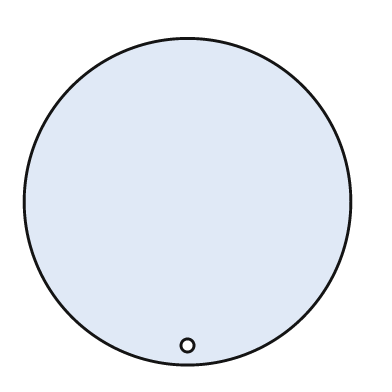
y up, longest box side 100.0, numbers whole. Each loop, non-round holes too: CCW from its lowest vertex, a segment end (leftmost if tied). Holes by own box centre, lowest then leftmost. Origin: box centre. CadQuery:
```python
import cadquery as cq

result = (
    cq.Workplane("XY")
    .moveTo(0.0, 0.0)
    .circle(50.0)
    .moveTo(0.0, -44.0)
    .circle(2.0)
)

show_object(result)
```